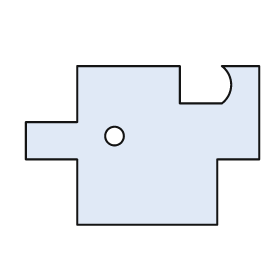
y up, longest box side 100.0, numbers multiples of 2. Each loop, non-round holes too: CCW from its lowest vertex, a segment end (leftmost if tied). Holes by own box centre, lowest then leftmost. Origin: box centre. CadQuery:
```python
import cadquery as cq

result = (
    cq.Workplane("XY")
    .moveTo(-28.0, -34.0)
    .lineTo(32.0, -34.0)
    .lineTo(32.0, -6.0)
    .lineTo(50.0, -6.0)
    .lineTo(50.0, 34.0)
    .lineTo(34.0, 34.0)
    .threePointArc((38.0, 26.0), (34.0, 18.0))
    .lineTo(16.0, 18.0)
    .lineTo(16.0, 34.0)
    .lineTo(-28.0, 34.0)
    .lineTo(-28.0, 10.0)
    .lineTo(-50.0, 10.0)
    .lineTo(-50.0, -6.0)
    .lineTo(-28.0, -6.0)
    .close()
    .moveTo(-12.0, 4.0)
    .circle(4.0)
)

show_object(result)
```